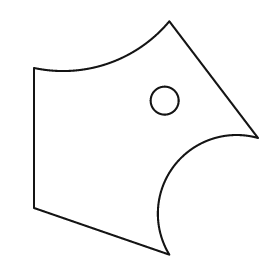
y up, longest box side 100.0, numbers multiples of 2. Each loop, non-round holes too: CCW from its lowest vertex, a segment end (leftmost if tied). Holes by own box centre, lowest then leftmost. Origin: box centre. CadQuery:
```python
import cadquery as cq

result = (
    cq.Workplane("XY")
    .moveTo(10.0, -50.0)
    .threePointArc((12.0, -12.0), (48.0, 0.0))
    .lineTo(10.0, 50.0)
    .threePointArc((-16.0, 32.0), (-48.0, 30.0))
    .lineTo(-48.0, -30.0)
    .close()
    .moveTo(8.0, 16.0)
    .circle(6.0)
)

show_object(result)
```